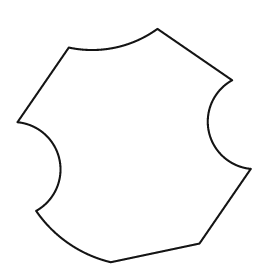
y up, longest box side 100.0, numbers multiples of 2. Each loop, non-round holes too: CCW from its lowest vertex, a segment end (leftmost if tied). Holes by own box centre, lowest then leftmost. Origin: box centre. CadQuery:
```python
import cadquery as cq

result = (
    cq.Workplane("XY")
    .moveTo(-10.0, -50.0)
    .lineTo(28.0, -42.0)
    .lineTo(50.0, -10.0)
    .threePointArc((32.0, 6.0), (42.0, 28.0))
    .lineTo(10.0, 50.0)
    .threePointArc((-8.0, 42.0), (-28.0, 42.0))
    .lineTo(-50.0, 10.0)
    .threePointArc((-32.0, -6.0), (-42.0, -28.0))
    .threePointArc((-28.0, -42.0), (-10.0, -50.0))
    .close()
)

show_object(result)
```